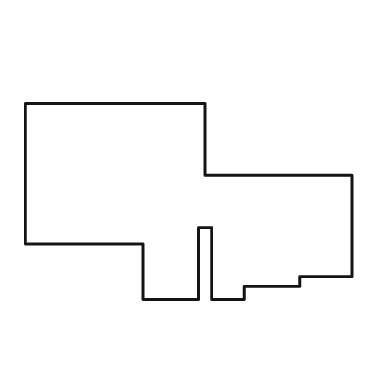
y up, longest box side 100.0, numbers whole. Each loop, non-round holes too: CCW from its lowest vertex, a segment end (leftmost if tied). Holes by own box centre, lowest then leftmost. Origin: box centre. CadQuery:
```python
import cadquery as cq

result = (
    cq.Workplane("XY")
    .moveTo(-14.0, -30.0)
    .lineTo(3.0, -30.0)
    .lineTo(3.0, -8.0)
    .lineTo(7.0, -8.0)
    .lineTo(7.0, -30.0)
    .lineTo(17.0, -30.0)
    .lineTo(17.0, -26.0)
    .lineTo(34.0, -26.0)
    .lineTo(34.0, -23.0)
    .lineTo(50.0, -23.0)
    .lineTo(50.0, 8.0)
    .lineTo(5.0, 8.0)
    .lineTo(5.0, 30.0)
    .lineTo(-50.0, 30.0)
    .lineTo(-50.0, -13.0)
    .lineTo(-14.0, -13.0)
    .close()
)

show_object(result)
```